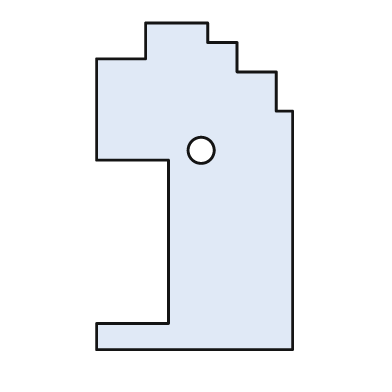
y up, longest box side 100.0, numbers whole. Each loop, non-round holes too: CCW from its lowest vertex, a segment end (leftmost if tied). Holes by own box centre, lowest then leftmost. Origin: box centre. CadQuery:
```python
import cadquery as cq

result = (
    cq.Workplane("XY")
    .moveTo(-30.0, -50.0)
    .lineTo(30.0, -50.0)
    .lineTo(30.0, 23.0)
    .lineTo(25.0, 23.0)
    .lineTo(25.0, 35.0)
    .lineTo(13.0, 35.0)
    .lineTo(13.0, 44.0)
    .lineTo(4.0, 44.0)
    .lineTo(4.0, 50.0)
    .lineTo(-15.0, 50.0)
    .lineTo(-15.0, 39.0)
    .lineTo(-30.0, 39.0)
    .lineTo(-30.0, 8.0)
    .lineTo(-8.0, 8.0)
    .lineTo(-8.0, -42.0)
    .lineTo(-30.0, -42.0)
    .close()
    .moveTo(2.0, 11.0)
    .circle(4.0)
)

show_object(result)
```